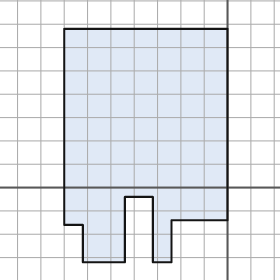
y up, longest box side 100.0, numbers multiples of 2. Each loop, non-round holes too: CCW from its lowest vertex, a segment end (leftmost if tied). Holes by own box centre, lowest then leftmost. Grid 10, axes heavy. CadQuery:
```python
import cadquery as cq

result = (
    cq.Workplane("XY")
    .moveTo(-62.0, -32.0)
    .lineTo(-44.0, -32.0)
    .lineTo(-44.0, -4.0)
    .lineTo(-32.0, -4.0)
    .lineTo(-32.0, -32.0)
    .lineTo(-24.0, -32.0)
    .lineTo(-24.0, -14.0)
    .lineTo(0.0, -14.0)
    .lineTo(0.0, 68.0)
    .lineTo(-70.0, 68.0)
    .lineTo(-70.0, -16.0)
    .lineTo(-62.0, -16.0)
    .close()
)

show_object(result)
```